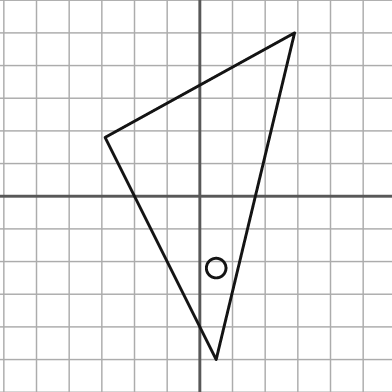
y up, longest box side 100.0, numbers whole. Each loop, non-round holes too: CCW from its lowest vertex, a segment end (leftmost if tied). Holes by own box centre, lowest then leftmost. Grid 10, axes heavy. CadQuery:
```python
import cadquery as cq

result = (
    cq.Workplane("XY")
    .moveTo(5.0, -50.0)
    .lineTo(29.0, 50.0)
    .lineTo(-29.0, 18.0)
    .close()
    .moveTo(5.0, -22.0)
    .circle(3.0)
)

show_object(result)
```